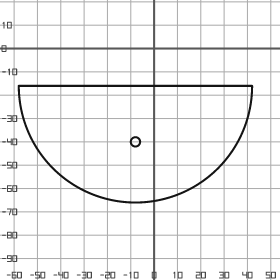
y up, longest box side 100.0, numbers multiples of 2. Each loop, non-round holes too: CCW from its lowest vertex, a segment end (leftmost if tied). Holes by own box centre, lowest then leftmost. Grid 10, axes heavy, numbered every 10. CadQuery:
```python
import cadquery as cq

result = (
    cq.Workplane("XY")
    .moveTo(-58.0, -16.0)
    .threePointArc((-8.0, -66.0), (42.0, -16.0))
    .close()
    .moveTo(-8.0, -40.0)
    .circle(2.0)
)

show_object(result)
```